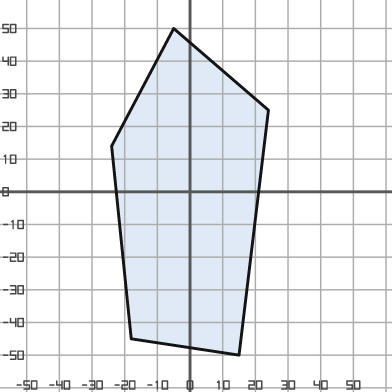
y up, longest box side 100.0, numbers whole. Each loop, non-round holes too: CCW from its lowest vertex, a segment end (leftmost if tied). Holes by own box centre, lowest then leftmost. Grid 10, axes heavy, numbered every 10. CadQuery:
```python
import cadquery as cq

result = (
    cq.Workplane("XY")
    .moveTo(15.0, -50.0)
    .lineTo(24.0, 25.0)
    .lineTo(-5.0, 50.0)
    .lineTo(-24.0, 14.0)
    .lineTo(-18.0, -45.0)
    .close()
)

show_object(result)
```